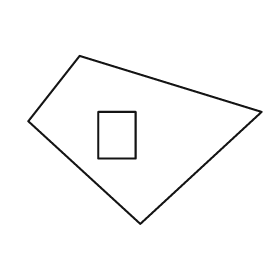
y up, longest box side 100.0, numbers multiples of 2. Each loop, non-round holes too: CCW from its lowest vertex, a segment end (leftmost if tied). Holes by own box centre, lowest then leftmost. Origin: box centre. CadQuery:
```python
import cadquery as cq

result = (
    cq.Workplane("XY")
    .moveTo(-2.0, -36.0)
    .lineTo(50.0, 12.0)
    .lineTo(-28.0, 36.0)
    .lineTo(-50.0, 8.0)
    .close()
    .moveTo(-20.0, -8.0)
    .lineTo(-4.0, -8.0)
    .lineTo(-4.0, 12.0)
    .lineTo(-20.0, 12.0)
    .close()
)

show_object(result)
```